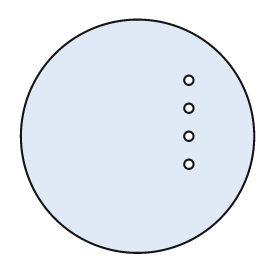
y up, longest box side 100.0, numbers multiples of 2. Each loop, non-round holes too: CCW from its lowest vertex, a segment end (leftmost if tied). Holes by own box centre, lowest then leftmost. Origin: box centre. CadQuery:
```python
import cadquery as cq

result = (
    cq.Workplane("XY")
    .moveTo(0.0, 0.0)
    .circle(50.0)
    .moveTo(22.0, -12.0)
    .circle(2.0)
    .moveTo(22.0, 0.0)
    .circle(2.0)
    .moveTo(22.0, 12.0)
    .circle(2.0)
    .moveTo(22.0, 24.0)
    .circle(2.0)
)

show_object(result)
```